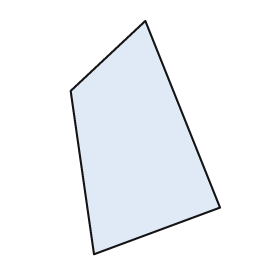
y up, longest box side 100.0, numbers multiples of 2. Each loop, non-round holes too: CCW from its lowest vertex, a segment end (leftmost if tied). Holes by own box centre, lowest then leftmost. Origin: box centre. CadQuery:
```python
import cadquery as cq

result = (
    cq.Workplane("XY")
    .moveTo(-22.0, -50.0)
    .lineTo(32.0, -30.0)
    .lineTo(0.0, 50.0)
    .lineTo(-32.0, 20.0)
    .close()
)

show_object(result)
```